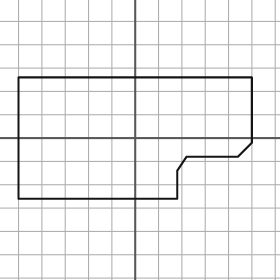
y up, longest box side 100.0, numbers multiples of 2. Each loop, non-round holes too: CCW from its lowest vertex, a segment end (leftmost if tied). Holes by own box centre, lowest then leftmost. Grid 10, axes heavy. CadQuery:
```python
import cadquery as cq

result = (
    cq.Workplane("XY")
    .moveTo(-50.0, -26.0)
    .lineTo(18.0, -26.0)
    .lineTo(18.0, -14.0)
    .lineTo(22.0, -8.0)
    .lineTo(44.0, -8.0)
    .lineTo(50.0, -2.0)
    .lineTo(50.0, 26.0)
    .lineTo(-50.0, 26.0)
    .close()
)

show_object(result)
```